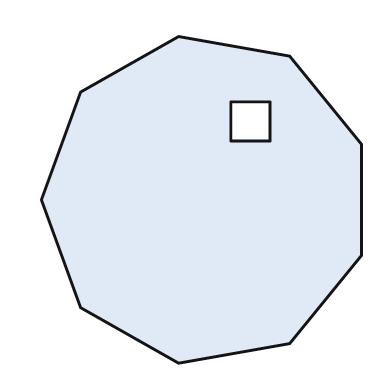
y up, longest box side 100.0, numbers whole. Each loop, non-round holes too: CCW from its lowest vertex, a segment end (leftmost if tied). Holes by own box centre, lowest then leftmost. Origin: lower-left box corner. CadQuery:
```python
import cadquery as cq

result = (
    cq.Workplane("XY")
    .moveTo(42.0, 0.0)
    .lineTo(76.0, 6.0)
    .lineTo(98.0, 33.0)
    .lineTo(98.0, 67.0)
    .lineTo(76.0, 94.0)
    .lineTo(42.0, 100.0)
    .lineTo(12.0, 83.0)
    .lineTo(0.0, 50.0)
    .lineTo(12.0, 17.0)
    .close()
    .moveTo(58.0, 68.0)
    .lineTo(70.0, 68.0)
    .lineTo(70.0, 80.0)
    .lineTo(58.0, 80.0)
    .close()
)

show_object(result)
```